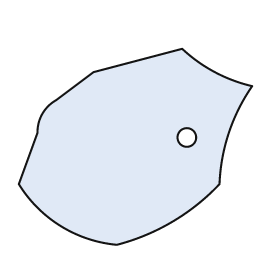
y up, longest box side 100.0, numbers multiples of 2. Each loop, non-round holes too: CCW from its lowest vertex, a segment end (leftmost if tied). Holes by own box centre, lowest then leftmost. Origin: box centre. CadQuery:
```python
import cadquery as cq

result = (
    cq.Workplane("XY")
    .moveTo(-8.0, -42.0)
    .threePointArc((16.0, -32.0), (36.0, -16.0))
    .threePointArc((40.0, 6.0), (50.0, 26.0))
    .threePointArc((34.0, 32.0), (20.0, 42.0))
    .lineTo(-18.0, 32.0)
    .lineTo(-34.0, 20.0)
    .threePointArc((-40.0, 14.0), (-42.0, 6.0))
    .lineTo(-50.0, -16.0)
    .threePointArc((-32.0, -34.0), (-8.0, -42.0))
    .close()
    .moveTo(22.0, 4.0)
    .circle(4.0)
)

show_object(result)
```